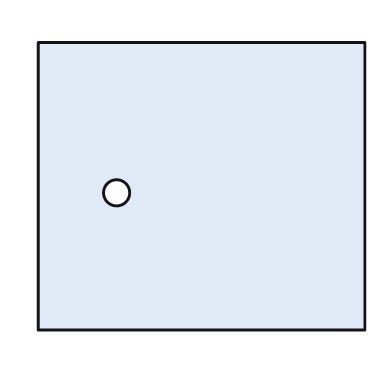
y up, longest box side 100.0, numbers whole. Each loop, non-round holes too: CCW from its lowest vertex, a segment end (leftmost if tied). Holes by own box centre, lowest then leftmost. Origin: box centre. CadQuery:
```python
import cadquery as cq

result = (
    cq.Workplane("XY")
    .moveTo(-50.0, -44.0)
    .lineTo(50.0, -44.0)
    .lineTo(50.0, 44.0)
    .lineTo(-50.0, 44.0)
    .close()
    .moveTo(-26.0, -2.0)
    .circle(4.0)
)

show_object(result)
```